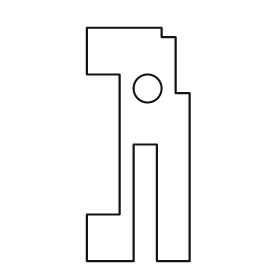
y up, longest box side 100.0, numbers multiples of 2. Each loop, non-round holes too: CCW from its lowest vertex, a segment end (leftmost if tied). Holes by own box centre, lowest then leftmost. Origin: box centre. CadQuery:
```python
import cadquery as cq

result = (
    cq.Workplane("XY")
    .moveTo(-22.0, -50.0)
    .lineTo(-2.0, -50.0)
    .lineTo(-2.0, 0.0)
    .lineTo(8.0, 0.0)
    .lineTo(8.0, -50.0)
    .lineTo(22.0, -50.0)
    .lineTo(22.0, 22.0)
    .lineTo(16.0, 22.0)
    .lineTo(16.0, 46.0)
    .lineTo(10.0, 46.0)
    .lineTo(10.0, 50.0)
    .lineTo(-22.0, 50.0)
    .lineTo(-22.0, 30.0)
    .lineTo(-8.0, 30.0)
    .lineTo(-8.0, -30.0)
    .lineTo(-22.0, -30.0)
    .close()
    .moveTo(4.0, 24.0)
    .circle(6.0)
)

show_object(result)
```